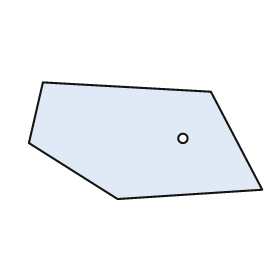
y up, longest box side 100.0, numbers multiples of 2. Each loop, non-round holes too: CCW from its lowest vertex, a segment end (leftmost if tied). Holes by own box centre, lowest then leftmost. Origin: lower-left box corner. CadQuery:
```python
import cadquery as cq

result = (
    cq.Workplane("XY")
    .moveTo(38.0, 0.0)
    .lineTo(100.0, 4.0)
    .lineTo(78.0, 46.0)
    .lineTo(6.0, 50.0)
    .lineTo(0.0, 24.0)
    .close()
    .moveTo(66.0, 26.0)
    .circle(2.0)
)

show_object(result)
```